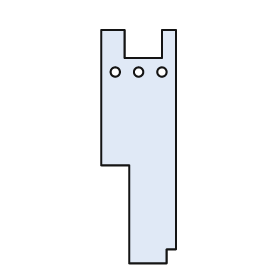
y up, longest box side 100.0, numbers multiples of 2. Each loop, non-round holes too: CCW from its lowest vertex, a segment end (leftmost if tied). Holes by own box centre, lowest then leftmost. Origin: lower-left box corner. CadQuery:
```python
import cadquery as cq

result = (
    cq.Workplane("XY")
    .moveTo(12.0, 0.0)
    .lineTo(28.0, 0.0)
    .lineTo(28.0, 6.0)
    .lineTo(32.0, 6.0)
    .lineTo(32.0, 100.0)
    .lineTo(26.0, 100.0)
    .lineTo(26.0, 88.0)
    .lineTo(10.0, 88.0)
    .lineTo(10.0, 100.0)
    .lineTo(0.0, 100.0)
    .lineTo(0.0, 42.0)
    .lineTo(12.0, 42.0)
    .close()
    .moveTo(6.0, 82.0)
    .circle(2.0)
    .moveTo(16.0, 82.0)
    .circle(2.0)
    .moveTo(26.0, 82.0)
    .circle(2.0)
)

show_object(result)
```